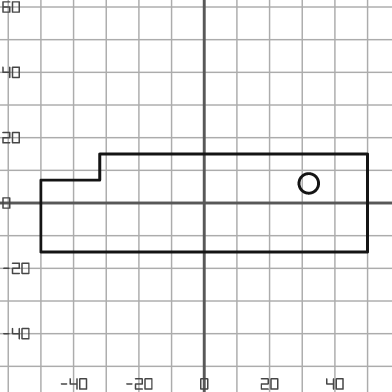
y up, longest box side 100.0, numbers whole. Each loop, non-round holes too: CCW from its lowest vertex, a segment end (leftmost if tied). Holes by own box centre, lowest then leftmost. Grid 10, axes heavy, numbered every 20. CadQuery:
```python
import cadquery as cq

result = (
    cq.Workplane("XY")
    .moveTo(-50.0, -15.0)
    .lineTo(50.0, -15.0)
    .lineTo(50.0, 15.0)
    .lineTo(-32.0, 15.0)
    .lineTo(-32.0, 7.0)
    .lineTo(-50.0, 7.0)
    .close()
    .moveTo(32.0, 6.0)
    .circle(3.0)
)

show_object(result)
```